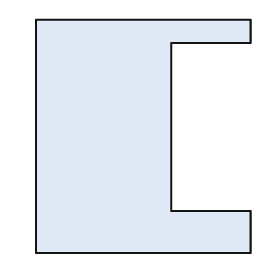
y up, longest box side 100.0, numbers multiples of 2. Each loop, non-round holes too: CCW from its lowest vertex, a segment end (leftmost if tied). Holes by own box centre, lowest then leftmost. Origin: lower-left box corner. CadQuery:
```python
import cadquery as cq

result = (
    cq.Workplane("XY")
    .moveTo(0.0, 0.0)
    .lineTo(92.0, 0.0)
    .lineTo(92.0, 18.0)
    .lineTo(58.0, 18.0)
    .lineTo(58.0, 90.0)
    .lineTo(92.0, 90.0)
    .lineTo(92.0, 100.0)
    .lineTo(0.0, 100.0)
    .close()
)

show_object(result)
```